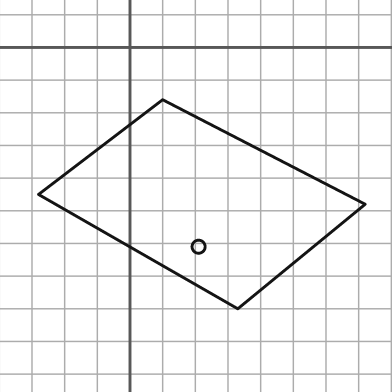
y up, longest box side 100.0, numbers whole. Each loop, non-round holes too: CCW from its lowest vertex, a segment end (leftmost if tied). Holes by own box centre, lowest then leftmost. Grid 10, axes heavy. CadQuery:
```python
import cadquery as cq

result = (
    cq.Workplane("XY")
    .moveTo(33.0, -80.0)
    .lineTo(72.0, -48.0)
    .lineTo(10.0, -16.0)
    .lineTo(-28.0, -45.0)
    .close()
    .moveTo(21.0, -61.0)
    .circle(2.0)
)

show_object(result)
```